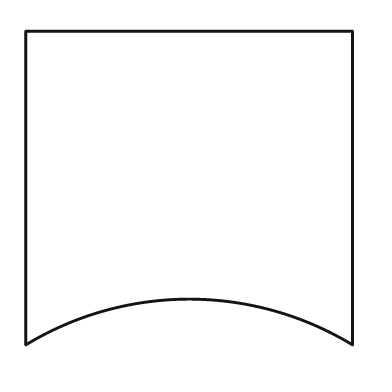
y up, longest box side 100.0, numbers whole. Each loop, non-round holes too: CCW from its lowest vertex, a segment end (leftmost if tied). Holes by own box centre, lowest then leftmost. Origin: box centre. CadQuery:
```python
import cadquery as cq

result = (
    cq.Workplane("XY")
    .moveTo(-50.0, -48.0)
    .threePointArc((0.0, -34.0), (50.0, -48.0))
    .lineTo(50.0, 48.0)
    .lineTo(-50.0, 48.0)
    .close()
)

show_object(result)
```